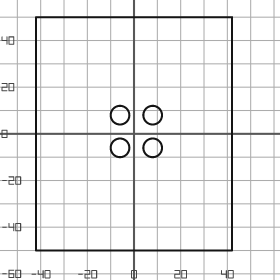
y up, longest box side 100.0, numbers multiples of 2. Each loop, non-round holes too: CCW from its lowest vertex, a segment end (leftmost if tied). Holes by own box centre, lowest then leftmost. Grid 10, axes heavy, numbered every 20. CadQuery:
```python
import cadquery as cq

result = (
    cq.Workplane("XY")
    .moveTo(-42.0, -50.0)
    .lineTo(42.0, -50.0)
    .lineTo(42.0, 50.0)
    .lineTo(-42.0, 50.0)
    .close()
    .moveTo(-6.0, -6.0)
    .circle(4.0)
    .moveTo(8.0, -6.0)
    .circle(4.0)
    .moveTo(-6.0, 8.0)
    .circle(4.0)
    .moveTo(8.0, 8.0)
    .circle(4.0)
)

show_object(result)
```